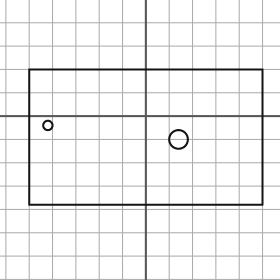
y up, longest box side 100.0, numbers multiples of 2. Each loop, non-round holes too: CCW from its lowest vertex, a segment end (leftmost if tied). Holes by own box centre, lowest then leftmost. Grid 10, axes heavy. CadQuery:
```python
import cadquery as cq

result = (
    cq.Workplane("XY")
    .moveTo(-50.0, -38.0)
    .lineTo(50.0, -38.0)
    .lineTo(50.0, 20.0)
    .lineTo(-50.0, 20.0)
    .close()
    .moveTo(14.0, -10.0)
    .circle(4.0)
    .moveTo(-42.0, -4.0)
    .circle(2.0)
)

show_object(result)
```